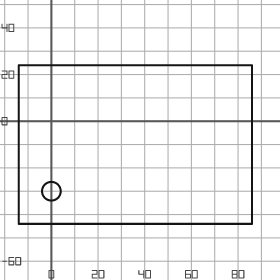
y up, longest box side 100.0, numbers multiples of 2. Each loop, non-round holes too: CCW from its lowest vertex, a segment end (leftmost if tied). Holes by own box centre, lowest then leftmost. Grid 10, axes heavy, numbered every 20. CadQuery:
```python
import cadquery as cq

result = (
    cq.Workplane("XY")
    .moveTo(-14.0, -44.0)
    .lineTo(86.0, -44.0)
    .lineTo(86.0, 24.0)
    .lineTo(-14.0, 24.0)
    .close()
    .moveTo(0.0, -30.0)
    .circle(4.0)
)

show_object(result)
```